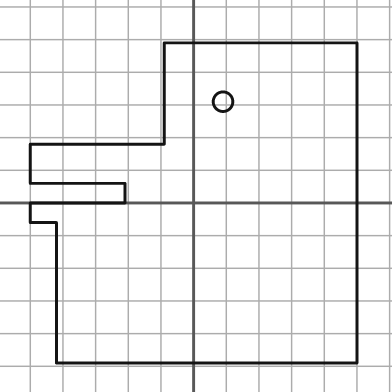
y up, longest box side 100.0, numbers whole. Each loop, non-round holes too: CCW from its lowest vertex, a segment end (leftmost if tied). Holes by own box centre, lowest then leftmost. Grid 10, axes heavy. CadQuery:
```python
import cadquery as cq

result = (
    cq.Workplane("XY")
    .moveTo(-42.0, -49.0)
    .lineTo(50.0, -49.0)
    .lineTo(50.0, 49.0)
    .lineTo(-9.0, 49.0)
    .lineTo(-9.0, 18.0)
    .lineTo(-50.0, 18.0)
    .lineTo(-50.0, 6.0)
    .lineTo(-21.0, 6.0)
    .lineTo(-21.0, 0.0)
    .lineTo(-50.0, 0.0)
    .lineTo(-50.0, -6.0)
    .lineTo(-42.0, -6.0)
    .close()
    .moveTo(9.0, 31.0)
    .circle(3.0)
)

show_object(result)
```